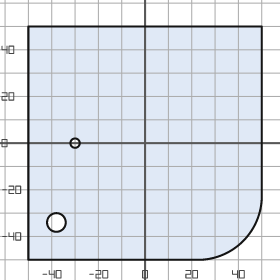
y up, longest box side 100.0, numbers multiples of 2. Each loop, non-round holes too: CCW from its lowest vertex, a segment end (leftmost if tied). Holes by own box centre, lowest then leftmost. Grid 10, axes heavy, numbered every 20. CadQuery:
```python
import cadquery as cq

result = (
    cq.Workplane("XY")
    .moveTo(-50.0, -50.0)
    .lineTo(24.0, -50.0)
    .threePointArc((42.0, -42.0), (50.0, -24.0))
    .lineTo(50.0, 50.0)
    .lineTo(-50.0, 50.0)
    .close()
    .moveTo(-38.0, -34.0)
    .circle(4.0)
    .moveTo(-30.0, 0.0)
    .circle(2.0)
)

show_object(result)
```